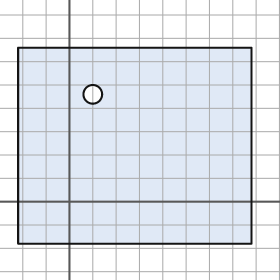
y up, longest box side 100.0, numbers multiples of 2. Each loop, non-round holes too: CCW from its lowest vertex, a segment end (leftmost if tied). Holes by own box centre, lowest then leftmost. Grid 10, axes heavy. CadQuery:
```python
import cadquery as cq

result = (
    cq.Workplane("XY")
    .moveTo(-22.0, -18.0)
    .lineTo(78.0, -18.0)
    .lineTo(78.0, 66.0)
    .lineTo(-22.0, 66.0)
    .close()
    .moveTo(10.0, 46.0)
    .circle(4.0)
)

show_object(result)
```